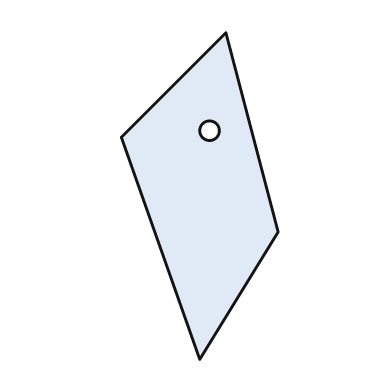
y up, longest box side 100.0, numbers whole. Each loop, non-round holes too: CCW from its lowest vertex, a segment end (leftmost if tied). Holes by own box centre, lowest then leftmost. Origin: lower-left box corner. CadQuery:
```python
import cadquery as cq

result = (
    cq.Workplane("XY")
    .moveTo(24.0, 0.0)
    .lineTo(48.0, 39.0)
    .lineTo(32.0, 100.0)
    .lineTo(0.0, 68.0)
    .close()
    .moveTo(27.0, 70.0)
    .circle(3.0)
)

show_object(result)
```